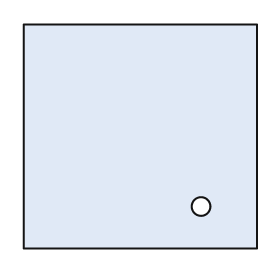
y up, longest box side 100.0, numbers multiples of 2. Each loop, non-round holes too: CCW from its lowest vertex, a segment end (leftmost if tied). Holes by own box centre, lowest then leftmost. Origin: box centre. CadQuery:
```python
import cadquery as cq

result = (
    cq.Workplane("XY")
    .moveTo(-50.0, -48.0)
    .lineTo(50.0, -48.0)
    .lineTo(50.0, 48.0)
    .lineTo(-50.0, 48.0)
    .close()
    .moveTo(26.0, -30.0)
    .circle(4.0)
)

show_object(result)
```